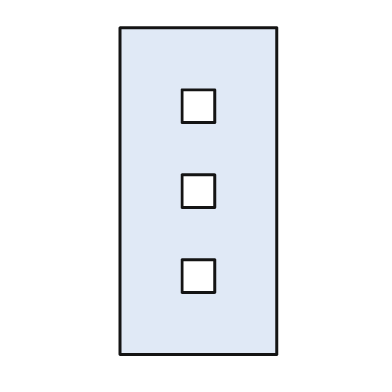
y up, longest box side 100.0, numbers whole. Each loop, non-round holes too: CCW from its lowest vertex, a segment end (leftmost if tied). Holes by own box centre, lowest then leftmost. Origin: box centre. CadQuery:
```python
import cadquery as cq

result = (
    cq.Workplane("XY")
    .moveTo(-24.0, -50.0)
    .lineTo(24.0, -50.0)
    .lineTo(24.0, 50.0)
    .lineTo(-24.0, 50.0)
    .close()
    .moveTo(-5.0, -31.0)
    .lineTo(5.0, -31.0)
    .lineTo(5.0, -21.0)
    .lineTo(-5.0, -21.0)
    .close()
    .moveTo(-5.0, -5.0)
    .lineTo(5.0, -5.0)
    .lineTo(5.0, 5.0)
    .lineTo(-5.0, 5.0)
    .close()
    .moveTo(-5.0, 21.0)
    .lineTo(5.0, 21.0)
    .lineTo(5.0, 31.0)
    .lineTo(-5.0, 31.0)
    .close()
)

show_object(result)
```